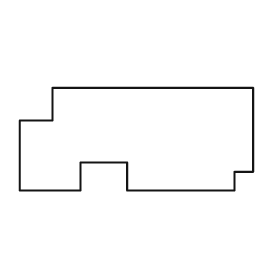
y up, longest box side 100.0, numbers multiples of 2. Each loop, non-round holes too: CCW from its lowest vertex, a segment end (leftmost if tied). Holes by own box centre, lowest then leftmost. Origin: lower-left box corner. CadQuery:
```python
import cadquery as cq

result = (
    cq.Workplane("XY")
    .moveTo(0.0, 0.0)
    .lineTo(26.0, 0.0)
    .lineTo(26.0, 12.0)
    .lineTo(46.0, 12.0)
    .lineTo(46.0, 0.0)
    .lineTo(92.0, 0.0)
    .lineTo(92.0, 8.0)
    .lineTo(100.0, 8.0)
    .lineTo(100.0, 44.0)
    .lineTo(14.0, 44.0)
    .lineTo(14.0, 30.0)
    .lineTo(0.0, 30.0)
    .close()
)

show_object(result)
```